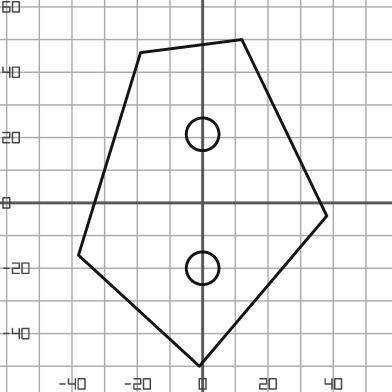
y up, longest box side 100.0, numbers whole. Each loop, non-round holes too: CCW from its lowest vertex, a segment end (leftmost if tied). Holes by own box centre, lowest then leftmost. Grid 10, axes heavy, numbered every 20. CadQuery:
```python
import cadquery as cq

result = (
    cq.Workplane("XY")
    .moveTo(-1.0, -50.0)
    .lineTo(38.0, -4.0)
    .lineTo(12.0, 50.0)
    .lineTo(-19.0, 46.0)
    .lineTo(-38.0, -16.0)
    .close()
    .moveTo(0.0, -20.0)
    .circle(5.0)
    .moveTo(0.0, 21.0)
    .circle(5.0)
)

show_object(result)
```